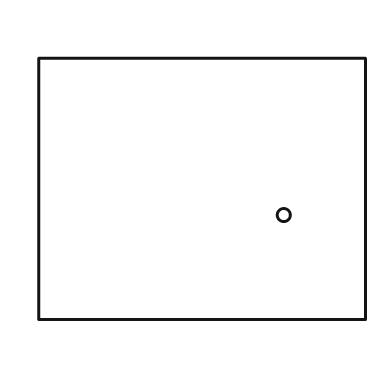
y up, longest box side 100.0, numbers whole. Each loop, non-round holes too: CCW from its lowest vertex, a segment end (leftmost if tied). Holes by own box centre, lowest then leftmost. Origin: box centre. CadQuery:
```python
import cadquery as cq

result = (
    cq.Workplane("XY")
    .moveTo(-50.0, -40.0)
    .lineTo(50.0, -40.0)
    .lineTo(50.0, 40.0)
    .lineTo(-50.0, 40.0)
    .close()
    .moveTo(25.0, -8.0)
    .circle(2.0)
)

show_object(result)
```